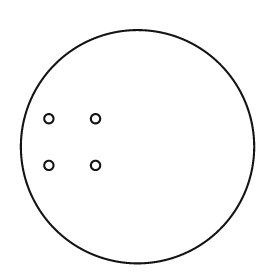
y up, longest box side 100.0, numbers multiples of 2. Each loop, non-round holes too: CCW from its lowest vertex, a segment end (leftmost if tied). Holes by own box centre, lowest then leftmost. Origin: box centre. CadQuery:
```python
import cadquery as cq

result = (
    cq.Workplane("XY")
    .moveTo(0.0, 0.0)
    .circle(50.0)
    .moveTo(-38.0, -8.0)
    .circle(2.0)
    .moveTo(-18.0, -8.0)
    .circle(2.0)
    .moveTo(-38.0, 12.0)
    .circle(2.0)
    .moveTo(-18.0, 12.0)
    .circle(2.0)
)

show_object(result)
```